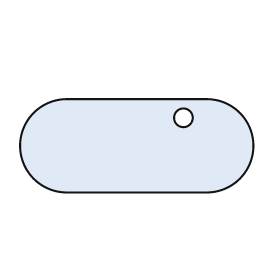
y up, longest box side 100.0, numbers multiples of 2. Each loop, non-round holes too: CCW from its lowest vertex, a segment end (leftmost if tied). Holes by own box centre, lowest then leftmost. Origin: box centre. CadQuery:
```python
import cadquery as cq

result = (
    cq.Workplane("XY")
    .moveTo(-30.0, -20.0)
    .lineTo(30.0, -20.0)
    .threePointArc((50.0, 0.0), (30.0, 20.0))
    .lineTo(-30.0, 20.0)
    .threePointArc((-50.0, 0.0), (-30.0, -20.0))
    .close()
    .moveTo(20.0, 12.0)
    .circle(4.0)
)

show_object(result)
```